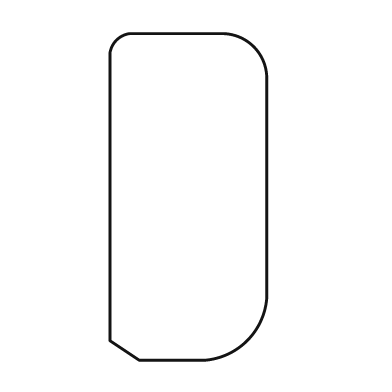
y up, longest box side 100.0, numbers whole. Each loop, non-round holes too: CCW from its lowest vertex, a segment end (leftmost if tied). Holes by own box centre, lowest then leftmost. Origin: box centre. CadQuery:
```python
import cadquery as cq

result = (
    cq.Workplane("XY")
    .moveTo(-15.0, -50.0)
    .lineTo(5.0, -50.0)
    .threePointArc((18.0, -44.0), (24.0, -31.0))
    .lineTo(24.0, 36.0)
    .threePointArc((20.0, 46.0), (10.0, 50.0))
    .lineTo(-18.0, 50.0)
    .threePointArc((-22.0, 48.0), (-24.0, 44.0))
    .lineTo(-24.0, -44.0)
    .close()
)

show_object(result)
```